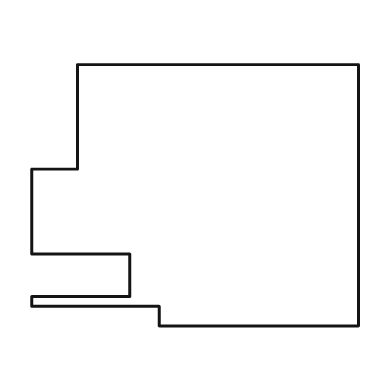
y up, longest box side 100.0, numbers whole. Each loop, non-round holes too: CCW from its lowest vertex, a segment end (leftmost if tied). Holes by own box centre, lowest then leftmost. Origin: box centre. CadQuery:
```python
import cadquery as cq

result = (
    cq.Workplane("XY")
    .moveTo(-11.0, -40.0)
    .lineTo(50.0, -40.0)
    .lineTo(50.0, 40.0)
    .lineTo(-36.0, 40.0)
    .lineTo(-36.0, 8.0)
    .lineTo(-50.0, 8.0)
    .lineTo(-50.0, -18.0)
    .lineTo(-20.0, -18.0)
    .lineTo(-20.0, -31.0)
    .lineTo(-50.0, -31.0)
    .lineTo(-50.0, -34.0)
    .lineTo(-11.0, -34.0)
    .close()
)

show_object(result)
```